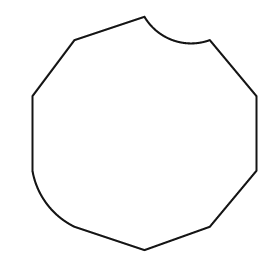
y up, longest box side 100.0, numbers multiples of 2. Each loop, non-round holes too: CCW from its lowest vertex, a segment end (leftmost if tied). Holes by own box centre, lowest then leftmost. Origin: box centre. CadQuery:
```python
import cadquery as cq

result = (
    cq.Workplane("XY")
    .moveTo(0.0, -50.0)
    .lineTo(28.0, -40.0)
    .lineTo(48.0, -16.0)
    .lineTo(48.0, 16.0)
    .lineTo(28.0, 40.0)
    .threePointArc((12.0, 40.0), (0.0, 50.0))
    .lineTo(-30.0, 40.0)
    .lineTo(-48.0, 16.0)
    .lineTo(-48.0, -16.0)
    .threePointArc((-42.0, -30.0), (-30.0, -40.0))
    .close()
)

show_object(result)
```